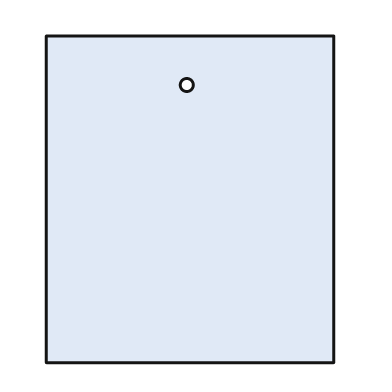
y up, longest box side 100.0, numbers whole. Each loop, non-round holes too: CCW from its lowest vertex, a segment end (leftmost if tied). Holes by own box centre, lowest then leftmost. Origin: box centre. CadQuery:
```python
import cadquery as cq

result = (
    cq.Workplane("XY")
    .moveTo(-44.0, -50.0)
    .lineTo(44.0, -50.0)
    .lineTo(44.0, 50.0)
    .lineTo(-44.0, 50.0)
    .close()
    .moveTo(-1.0, 35.0)
    .circle(2.0)
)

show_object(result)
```